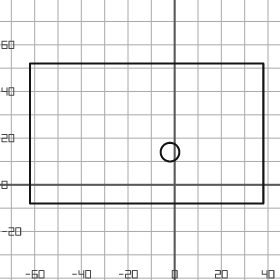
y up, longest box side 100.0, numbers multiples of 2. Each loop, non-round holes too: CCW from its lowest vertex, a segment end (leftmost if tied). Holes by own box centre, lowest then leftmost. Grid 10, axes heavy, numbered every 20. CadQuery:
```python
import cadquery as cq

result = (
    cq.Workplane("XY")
    .moveTo(-62.0, -8.0)
    .lineTo(38.0, -8.0)
    .lineTo(38.0, 52.0)
    .lineTo(-62.0, 52.0)
    .close()
    .moveTo(-2.0, 14.0)
    .circle(4.0)
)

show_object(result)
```